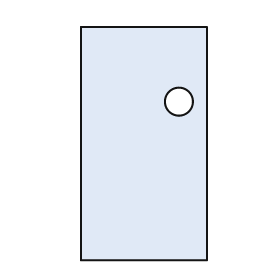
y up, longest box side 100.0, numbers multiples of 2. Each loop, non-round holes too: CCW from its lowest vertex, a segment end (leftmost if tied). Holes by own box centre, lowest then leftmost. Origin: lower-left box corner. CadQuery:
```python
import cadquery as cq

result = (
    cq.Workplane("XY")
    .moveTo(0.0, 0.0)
    .lineTo(54.0, 0.0)
    .lineTo(54.0, 100.0)
    .lineTo(0.0, 100.0)
    .close()
    .moveTo(42.0, 68.0)
    .circle(6.0)
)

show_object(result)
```